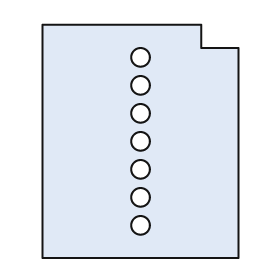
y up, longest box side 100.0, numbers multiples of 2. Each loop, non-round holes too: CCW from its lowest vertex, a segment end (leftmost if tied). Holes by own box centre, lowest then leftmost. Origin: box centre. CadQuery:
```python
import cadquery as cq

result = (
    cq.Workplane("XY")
    .moveTo(-42.0, -50.0)
    .lineTo(42.0, -50.0)
    .lineTo(42.0, 40.0)
    .lineTo(26.0, 40.0)
    .lineTo(26.0, 50.0)
    .lineTo(-42.0, 50.0)
    .close()
    .moveTo(0.0, -36.0)
    .circle(4.0)
    .moveTo(0.0, -24.0)
    .circle(4.0)
    .moveTo(0.0, -12.0)
    .circle(4.0)
    .moveTo(0.0, 0.0)
    .circle(4.0)
    .moveTo(0.0, 12.0)
    .circle(4.0)
    .moveTo(0.0, 24.0)
    .circle(4.0)
    .moveTo(0.0, 36.0)
    .circle(4.0)
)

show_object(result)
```